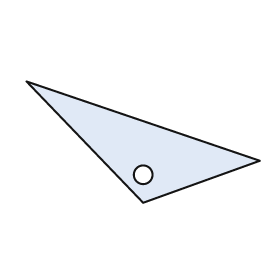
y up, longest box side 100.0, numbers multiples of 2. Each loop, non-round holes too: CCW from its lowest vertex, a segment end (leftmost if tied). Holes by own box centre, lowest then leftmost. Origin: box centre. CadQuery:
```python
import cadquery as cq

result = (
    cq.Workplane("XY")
    .moveTo(0.0, -26.0)
    .lineTo(50.0, -8.0)
    .lineTo(-50.0, 26.0)
    .close()
    .moveTo(0.0, -14.0)
    .circle(4.0)
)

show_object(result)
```